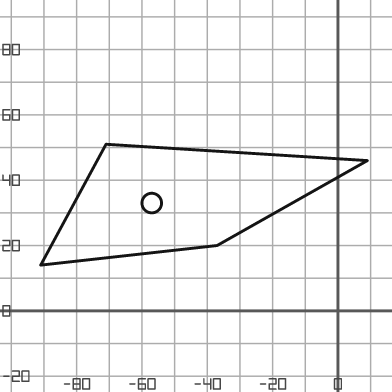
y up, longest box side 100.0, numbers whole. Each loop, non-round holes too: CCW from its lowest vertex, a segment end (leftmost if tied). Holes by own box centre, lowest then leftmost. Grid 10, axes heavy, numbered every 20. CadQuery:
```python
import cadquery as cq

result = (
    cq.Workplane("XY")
    .moveTo(-91.0, 14.0)
    .lineTo(-37.0, 20.0)
    .lineTo(9.0, 46.0)
    .lineTo(-71.0, 51.0)
    .close()
    .moveTo(-57.0, 33.0)
    .circle(3.0)
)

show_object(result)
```